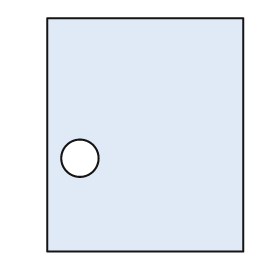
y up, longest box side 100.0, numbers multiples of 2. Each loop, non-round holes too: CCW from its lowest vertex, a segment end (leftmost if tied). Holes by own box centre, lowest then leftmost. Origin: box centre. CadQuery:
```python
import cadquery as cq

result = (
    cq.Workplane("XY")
    .moveTo(-42.0, -50.0)
    .lineTo(42.0, -50.0)
    .lineTo(42.0, 50.0)
    .lineTo(-42.0, 50.0)
    .close()
    .moveTo(-28.0, -10.0)
    .circle(8.0)
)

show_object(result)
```